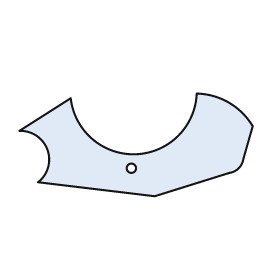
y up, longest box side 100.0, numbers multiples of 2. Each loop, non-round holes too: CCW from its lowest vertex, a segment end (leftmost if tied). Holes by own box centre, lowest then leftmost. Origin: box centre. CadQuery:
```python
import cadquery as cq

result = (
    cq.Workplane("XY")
    .moveTo(8.0, -22.0)
    .lineTo(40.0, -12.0)
    .threePointArc((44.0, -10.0), (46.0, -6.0))
    .lineTo(50.0, 8.0)
    .threePointArc((40.0, 18.0), (26.0, 22.0))
    .threePointArc((0.0, -4.0), (-28.0, 20.0))
    .lineTo(-50.0, 6.0)
    .threePointArc((-38.0, -2.0), (-42.0, -16.0))
    .close()
    .moveTo(-2.0, -10.0)
    .circle(2.0)
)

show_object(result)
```